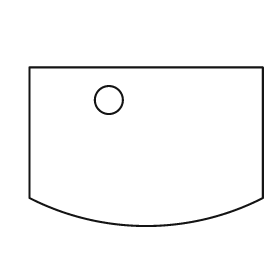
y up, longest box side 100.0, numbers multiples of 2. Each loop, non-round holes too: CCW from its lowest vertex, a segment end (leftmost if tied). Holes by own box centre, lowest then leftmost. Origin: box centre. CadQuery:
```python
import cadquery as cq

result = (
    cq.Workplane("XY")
    .moveTo(-50.0, -22.0)
    .threePointArc((0.0, -34.0), (50.0, -22.0))
    .lineTo(50.0, 34.0)
    .lineTo(-50.0, 34.0)
    .close()
    .moveTo(-16.0, 20.0)
    .circle(6.0)
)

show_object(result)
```